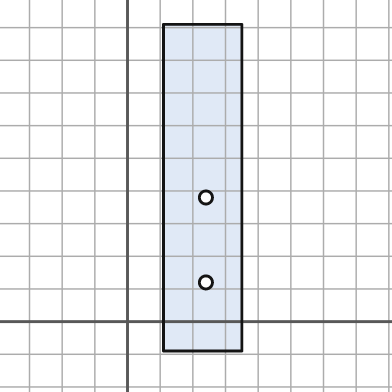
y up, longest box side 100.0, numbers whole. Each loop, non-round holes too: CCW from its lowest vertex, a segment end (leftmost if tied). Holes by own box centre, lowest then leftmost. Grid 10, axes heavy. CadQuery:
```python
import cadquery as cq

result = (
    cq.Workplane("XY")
    .moveTo(11.0, -9.0)
    .lineTo(35.0, -9.0)
    .lineTo(35.0, 91.0)
    .lineTo(11.0, 91.0)
    .close()
    .moveTo(24.0, 12.0)
    .circle(2.0)
    .moveTo(24.0, 38.0)
    .circle(2.0)
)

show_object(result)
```